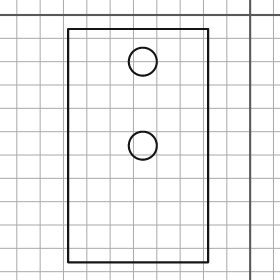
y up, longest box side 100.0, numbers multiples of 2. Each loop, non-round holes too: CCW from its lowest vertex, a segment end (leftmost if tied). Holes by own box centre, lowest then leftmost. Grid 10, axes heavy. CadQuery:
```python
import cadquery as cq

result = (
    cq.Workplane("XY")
    .moveTo(-78.0, -106.0)
    .lineTo(-18.0, -106.0)
    .lineTo(-18.0, -6.0)
    .lineTo(-78.0, -6.0)
    .close()
    .moveTo(-46.0, -56.0)
    .circle(6.0)
    .moveTo(-46.0, -20.0)
    .circle(6.0)
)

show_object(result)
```